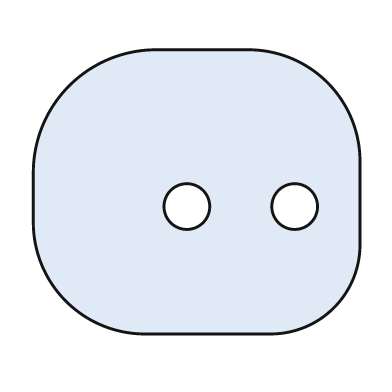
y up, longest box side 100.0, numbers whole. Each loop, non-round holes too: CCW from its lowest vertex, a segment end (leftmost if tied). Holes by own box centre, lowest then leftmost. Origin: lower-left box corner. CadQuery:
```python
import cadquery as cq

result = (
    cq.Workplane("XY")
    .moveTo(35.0, 0.0)
    .lineTo(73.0, 0.0)
    .threePointArc((92.0, 8.0), (100.0, 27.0))
    .lineTo(100.0, 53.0)
    .threePointArc((90.0, 77.0), (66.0, 87.0))
    .lineTo(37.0, 87.0)
    .threePointArc((11.0, 76.0), (0.0, 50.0))
    .lineTo(0.0, 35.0)
    .threePointArc((10.0, 10.0), (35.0, 0.0))
    .close()
    .moveTo(47.0, 39.0)
    .circle(7.0)
    .moveTo(80.0, 39.0)
    .circle(7.0)
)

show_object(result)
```